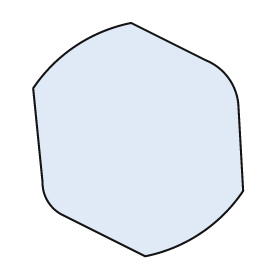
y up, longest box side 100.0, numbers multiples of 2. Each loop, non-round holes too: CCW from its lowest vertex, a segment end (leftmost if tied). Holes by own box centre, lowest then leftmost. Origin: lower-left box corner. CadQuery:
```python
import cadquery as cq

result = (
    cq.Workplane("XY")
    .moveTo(48.0, 0.0)
    .threePointArc((72.0, 10.0), (90.0, 28.0))
    .lineTo(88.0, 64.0)
    .threePointArc((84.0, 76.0), (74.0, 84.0))
    .lineTo(42.0, 100.0)
    .threePointArc((18.0, 90.0), (0.0, 72.0))
    .lineTo(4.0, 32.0)
    .threePointArc((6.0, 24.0), (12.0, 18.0))
    .close()
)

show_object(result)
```